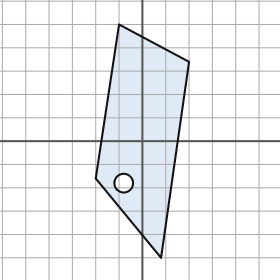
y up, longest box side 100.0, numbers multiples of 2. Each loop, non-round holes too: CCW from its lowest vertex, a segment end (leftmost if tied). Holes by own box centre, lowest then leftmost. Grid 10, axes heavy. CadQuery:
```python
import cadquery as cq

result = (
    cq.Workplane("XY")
    .moveTo(8.0, -50.0)
    .lineTo(20.0, 34.0)
    .lineTo(-10.0, 50.0)
    .lineTo(-20.0, -16.0)
    .close()
    .moveTo(-8.0, -18.0)
    .circle(4.0)
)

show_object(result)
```